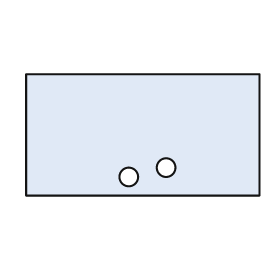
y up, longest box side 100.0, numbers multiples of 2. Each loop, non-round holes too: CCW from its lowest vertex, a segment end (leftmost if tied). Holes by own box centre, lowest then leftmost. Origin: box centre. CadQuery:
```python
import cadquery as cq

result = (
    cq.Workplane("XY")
    .moveTo(-50.0, -26.0)
    .lineTo(50.0, -26.0)
    .lineTo(50.0, 26.0)
    .lineTo(-50.0, 26.0)
    .close()
    .moveTo(-6.0, -18.0)
    .circle(4.0)
    .moveTo(10.0, -14.0)
    .circle(4.0)
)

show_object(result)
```